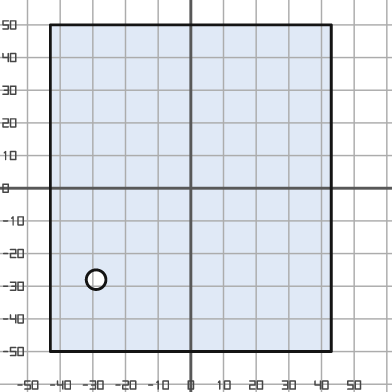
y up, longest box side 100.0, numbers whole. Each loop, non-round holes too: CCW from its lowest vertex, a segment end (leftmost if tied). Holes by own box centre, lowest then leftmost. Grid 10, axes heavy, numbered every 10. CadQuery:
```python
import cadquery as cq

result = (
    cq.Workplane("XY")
    .moveTo(-43.0, -50.0)
    .lineTo(43.0, -50.0)
    .lineTo(43.0, 50.0)
    .lineTo(-43.0, 50.0)
    .close()
    .moveTo(-29.0, -28.0)
    .circle(3.0)
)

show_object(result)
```